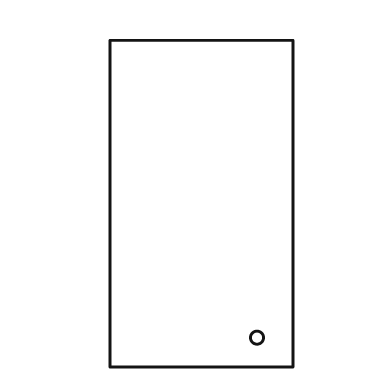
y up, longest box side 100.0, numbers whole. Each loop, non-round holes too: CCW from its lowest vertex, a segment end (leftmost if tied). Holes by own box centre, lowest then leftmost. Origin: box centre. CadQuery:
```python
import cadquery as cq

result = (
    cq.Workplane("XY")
    .moveTo(-28.0, -50.0)
    .lineTo(28.0, -50.0)
    .lineTo(28.0, 50.0)
    .lineTo(-28.0, 50.0)
    .close()
    .moveTo(17.0, -41.0)
    .circle(2.0)
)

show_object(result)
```